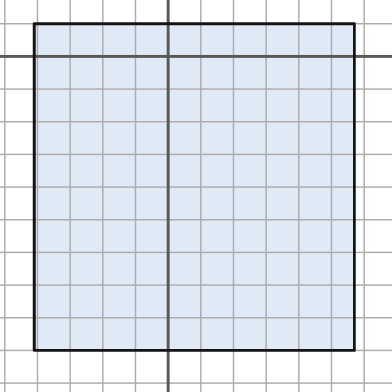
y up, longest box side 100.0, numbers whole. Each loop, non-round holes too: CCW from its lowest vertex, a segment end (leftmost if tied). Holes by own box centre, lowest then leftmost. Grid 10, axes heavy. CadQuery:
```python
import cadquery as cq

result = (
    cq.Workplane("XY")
    .moveTo(-41.0, -90.0)
    .lineTo(57.0, -90.0)
    .lineTo(57.0, 10.0)
    .lineTo(-41.0, 10.0)
    .close()
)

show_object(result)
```